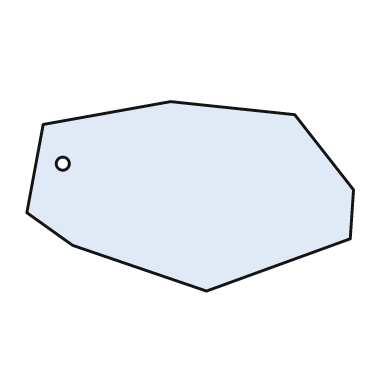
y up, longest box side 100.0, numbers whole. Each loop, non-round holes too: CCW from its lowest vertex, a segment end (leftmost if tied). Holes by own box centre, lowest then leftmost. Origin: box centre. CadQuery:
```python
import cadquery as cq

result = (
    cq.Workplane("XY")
    .moveTo(5.0, -29.0)
    .lineTo(49.0, -13.0)
    .lineTo(50.0, 2.0)
    .lineTo(32.0, 25.0)
    .lineTo(-6.0, 29.0)
    .lineTo(-45.0, 22.0)
    .lineTo(-50.0, -5.0)
    .lineTo(-36.0, -15.0)
    .close()
    .moveTo(-39.0, 10.0)
    .circle(2.0)
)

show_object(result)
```